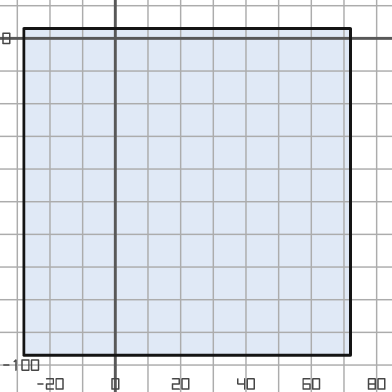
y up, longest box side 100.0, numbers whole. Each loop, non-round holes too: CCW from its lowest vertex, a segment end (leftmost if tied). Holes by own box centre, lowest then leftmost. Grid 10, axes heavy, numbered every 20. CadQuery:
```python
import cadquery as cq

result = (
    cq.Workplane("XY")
    .moveTo(-28.0, -97.0)
    .lineTo(72.0, -97.0)
    .lineTo(72.0, 3.0)
    .lineTo(-28.0, 3.0)
    .close()
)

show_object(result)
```